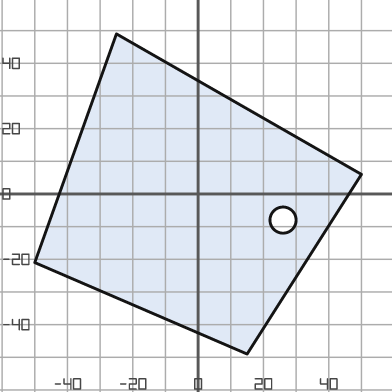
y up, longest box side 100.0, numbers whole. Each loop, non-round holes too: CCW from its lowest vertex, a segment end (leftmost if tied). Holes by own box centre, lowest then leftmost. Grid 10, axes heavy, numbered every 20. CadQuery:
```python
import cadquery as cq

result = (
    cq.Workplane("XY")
    .moveTo(15.0, -49.0)
    .lineTo(50.0, 6.0)
    .lineTo(-25.0, 49.0)
    .lineTo(-50.0, -21.0)
    .close()
    .moveTo(26.0, -8.0)
    .circle(4.0)
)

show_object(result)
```